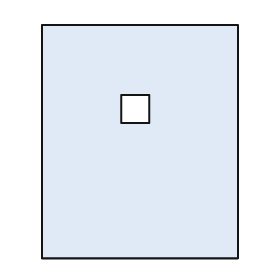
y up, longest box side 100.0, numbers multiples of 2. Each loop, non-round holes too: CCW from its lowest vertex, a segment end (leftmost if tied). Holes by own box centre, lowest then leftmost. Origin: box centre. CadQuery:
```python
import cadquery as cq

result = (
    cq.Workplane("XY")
    .moveTo(-42.0, -50.0)
    .lineTo(42.0, -50.0)
    .lineTo(42.0, 50.0)
    .lineTo(-42.0, 50.0)
    .close()
    .moveTo(-8.0, 8.0)
    .lineTo(4.0, 8.0)
    .lineTo(4.0, 20.0)
    .lineTo(-8.0, 20.0)
    .close()
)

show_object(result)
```